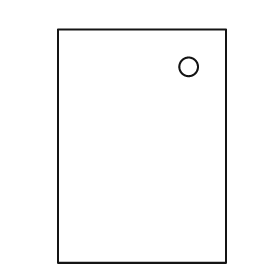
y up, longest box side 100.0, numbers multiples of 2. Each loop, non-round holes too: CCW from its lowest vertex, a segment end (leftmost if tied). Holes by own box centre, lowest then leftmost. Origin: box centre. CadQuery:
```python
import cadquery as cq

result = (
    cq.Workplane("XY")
    .moveTo(-36.0, -50.0)
    .lineTo(36.0, -50.0)
    .lineTo(36.0, 50.0)
    .lineTo(-36.0, 50.0)
    .close()
    .moveTo(20.0, 34.0)
    .circle(4.0)
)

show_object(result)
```